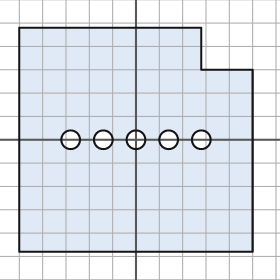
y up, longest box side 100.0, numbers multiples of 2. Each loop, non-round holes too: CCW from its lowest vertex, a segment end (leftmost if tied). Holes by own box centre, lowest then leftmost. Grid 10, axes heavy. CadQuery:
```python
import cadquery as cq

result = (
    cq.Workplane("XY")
    .moveTo(-50.0, -48.0)
    .lineTo(50.0, -48.0)
    .lineTo(50.0, 30.0)
    .lineTo(28.0, 30.0)
    .lineTo(28.0, 48.0)
    .lineTo(-50.0, 48.0)
    .close()
    .moveTo(-28.0, 0.0)
    .circle(4.0)
    .moveTo(-14.0, 0.0)
    .circle(4.0)
    .moveTo(0.0, 0.0)
    .circle(4.0)
    .moveTo(14.0, 0.0)
    .circle(4.0)
    .moveTo(28.0, 0.0)
    .circle(4.0)
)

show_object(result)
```